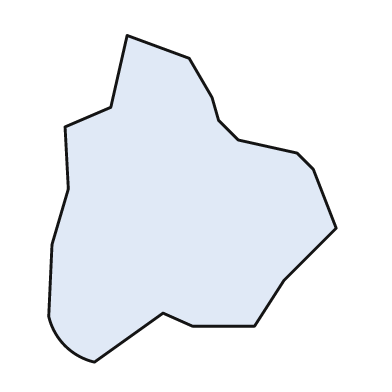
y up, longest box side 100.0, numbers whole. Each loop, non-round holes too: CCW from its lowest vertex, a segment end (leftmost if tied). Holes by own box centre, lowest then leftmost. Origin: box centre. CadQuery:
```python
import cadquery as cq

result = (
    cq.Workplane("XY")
    .moveTo(-30.0, -50.0)
    .lineTo(-9.0, -35.0)
    .lineTo(0.0, -39.0)
    .lineTo(19.0, -39.0)
    .lineTo(28.0, -25.0)
    .lineTo(44.0, -9.0)
    .lineTo(37.0, 9.0)
    .lineTo(32.0, 14.0)
    .lineTo(14.0, 18.0)
    .lineTo(8.0, 24.0)
    .lineTo(6.0, 31.0)
    .lineTo(-1.0, 43.0)
    .lineTo(-20.0, 50.0)
    .lineTo(-25.0, 28.0)
    .lineTo(-39.0, 22.0)
    .lineTo(-38.0, 3.0)
    .lineTo(-43.0, -14.0)
    .lineTo(-44.0, -36.0)
    .threePointArc((-39.0, -45.0), (-30.0, -50.0))
    .close()
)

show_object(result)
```